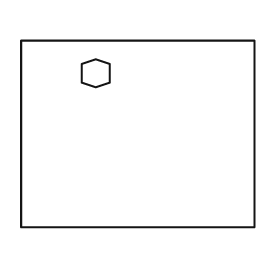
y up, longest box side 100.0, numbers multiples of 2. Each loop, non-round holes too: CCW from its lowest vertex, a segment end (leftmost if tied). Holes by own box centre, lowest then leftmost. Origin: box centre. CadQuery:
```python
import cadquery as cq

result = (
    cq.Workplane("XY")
    .moveTo(-50.0, -40.0)
    .lineTo(50.0, -40.0)
    .lineTo(50.0, 40.0)
    .lineTo(-50.0, 40.0)
    .close()
    .moveTo(-18.0, 20.0)
    .lineTo(-12.0, 22.0)
    .lineTo(-12.0, 30.0)
    .lineTo(-18.0, 32.0)
    .lineTo(-24.0, 30.0)
    .lineTo(-24.0, 22.0)
    .close()
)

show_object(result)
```